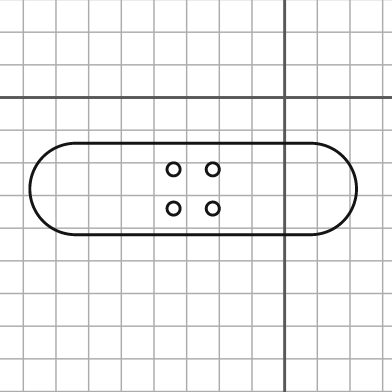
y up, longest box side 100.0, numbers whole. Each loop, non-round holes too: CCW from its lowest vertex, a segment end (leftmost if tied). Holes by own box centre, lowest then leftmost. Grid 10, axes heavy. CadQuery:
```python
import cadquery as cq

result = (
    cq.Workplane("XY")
    .moveTo(-64.0, -42.0)
    .lineTo(8.0, -42.0)
    .threePointArc((22.0, -28.0), (8.0, -14.0))
    .lineTo(-64.0, -14.0)
    .threePointArc((-78.0, -28.0), (-64.0, -42.0))
    .close()
    .moveTo(-34.0, -34.0)
    .circle(2.0)
    .moveTo(-22.0, -34.0)
    .circle(2.0)
    .moveTo(-34.0, -22.0)
    .circle(2.0)
    .moveTo(-22.0, -22.0)
    .circle(2.0)
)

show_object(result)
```